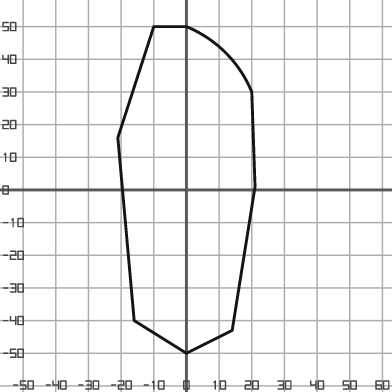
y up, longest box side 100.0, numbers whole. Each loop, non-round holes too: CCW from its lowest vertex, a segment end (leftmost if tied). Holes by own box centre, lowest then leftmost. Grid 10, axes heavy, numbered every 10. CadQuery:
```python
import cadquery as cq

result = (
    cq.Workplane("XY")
    .moveTo(0.0, -50.0)
    .lineTo(14.0, -43.0)
    .lineTo(21.0, 1.0)
    .lineTo(20.0, 30.0)
    .threePointArc((12.0, 42.0), (0.0, 50.0))
    .lineTo(-10.0, 50.0)
    .lineTo(-21.0, 16.0)
    .lineTo(-16.0, -40.0)
    .close()
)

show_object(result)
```